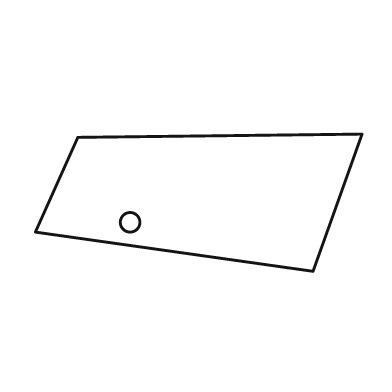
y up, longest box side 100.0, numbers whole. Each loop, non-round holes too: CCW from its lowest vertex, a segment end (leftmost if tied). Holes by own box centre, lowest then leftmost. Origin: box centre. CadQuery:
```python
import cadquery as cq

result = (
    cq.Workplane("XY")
    .moveTo(35.0, -21.0)
    .lineTo(50.0, 21.0)
    .lineTo(-37.0, 20.0)
    .lineTo(-50.0, -9.0)
    .close()
    .moveTo(-21.0, -6.0)
    .circle(3.0)
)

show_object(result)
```